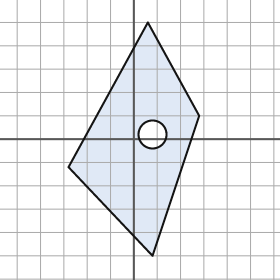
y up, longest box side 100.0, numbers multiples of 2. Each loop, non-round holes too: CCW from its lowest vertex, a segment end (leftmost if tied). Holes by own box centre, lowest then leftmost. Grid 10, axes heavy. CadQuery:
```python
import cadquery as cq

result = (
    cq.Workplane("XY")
    .moveTo(8.0, -50.0)
    .lineTo(28.0, 10.0)
    .lineTo(6.0, 50.0)
    .lineTo(-28.0, -12.0)
    .close()
    .moveTo(8.0, 2.0)
    .circle(6.0)
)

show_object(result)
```